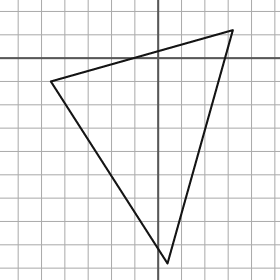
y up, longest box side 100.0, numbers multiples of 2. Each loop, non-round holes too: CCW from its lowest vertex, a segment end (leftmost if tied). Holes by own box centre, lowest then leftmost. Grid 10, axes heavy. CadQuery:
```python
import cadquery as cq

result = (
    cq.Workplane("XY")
    .moveTo(4.0, -88.0)
    .lineTo(32.0, 12.0)
    .lineTo(-46.0, -10.0)
    .close()
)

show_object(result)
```